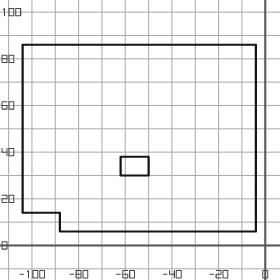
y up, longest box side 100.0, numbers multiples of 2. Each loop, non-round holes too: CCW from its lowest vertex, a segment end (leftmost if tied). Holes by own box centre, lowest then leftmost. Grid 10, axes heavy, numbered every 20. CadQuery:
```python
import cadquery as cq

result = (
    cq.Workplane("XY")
    .moveTo(-88.0, 6.0)
    .lineTo(-4.0, 6.0)
    .lineTo(-4.0, 86.0)
    .lineTo(-104.0, 86.0)
    .lineTo(-104.0, 14.0)
    .lineTo(-88.0, 14.0)
    .close()
    .moveTo(-62.0, 30.0)
    .lineTo(-50.0, 30.0)
    .lineTo(-50.0, 38.0)
    .lineTo(-62.0, 38.0)
    .close()
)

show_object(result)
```